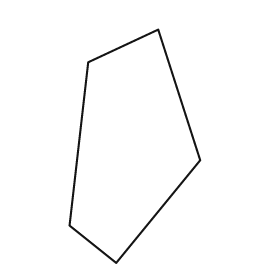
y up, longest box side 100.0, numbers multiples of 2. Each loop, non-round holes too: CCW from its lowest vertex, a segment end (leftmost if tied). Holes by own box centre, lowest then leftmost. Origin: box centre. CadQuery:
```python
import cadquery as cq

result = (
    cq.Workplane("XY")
    .moveTo(-8.0, -50.0)
    .lineTo(28.0, -6.0)
    .lineTo(10.0, 50.0)
    .lineTo(-20.0, 36.0)
    .lineTo(-28.0, -34.0)
    .close()
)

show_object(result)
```